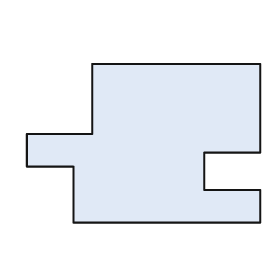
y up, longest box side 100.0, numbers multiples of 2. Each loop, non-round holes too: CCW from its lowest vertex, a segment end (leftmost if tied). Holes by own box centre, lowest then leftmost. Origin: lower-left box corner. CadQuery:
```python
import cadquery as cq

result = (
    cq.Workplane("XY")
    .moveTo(20.0, 0.0)
    .lineTo(100.0, 0.0)
    .lineTo(100.0, 14.0)
    .lineTo(76.0, 14.0)
    .lineTo(76.0, 30.0)
    .lineTo(100.0, 30.0)
    .lineTo(100.0, 68.0)
    .lineTo(28.0, 68.0)
    .lineTo(28.0, 38.0)
    .lineTo(0.0, 38.0)
    .lineTo(0.0, 24.0)
    .lineTo(20.0, 24.0)
    .close()
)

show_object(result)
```